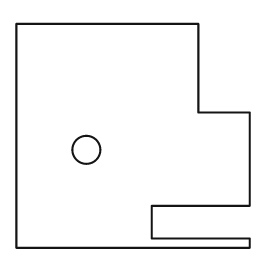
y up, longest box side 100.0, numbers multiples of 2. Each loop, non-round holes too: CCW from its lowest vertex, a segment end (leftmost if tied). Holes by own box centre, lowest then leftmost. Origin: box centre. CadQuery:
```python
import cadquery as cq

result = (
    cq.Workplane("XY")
    .moveTo(-50.0, -48.0)
    .lineTo(50.0, -48.0)
    .lineTo(50.0, -44.0)
    .lineTo(8.0, -44.0)
    .lineTo(8.0, -30.0)
    .lineTo(50.0, -30.0)
    .lineTo(50.0, 10.0)
    .lineTo(28.0, 10.0)
    .lineTo(28.0, 48.0)
    .lineTo(-50.0, 48.0)
    .close()
    .moveTo(-20.0, -6.0)
    .circle(6.0)
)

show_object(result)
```